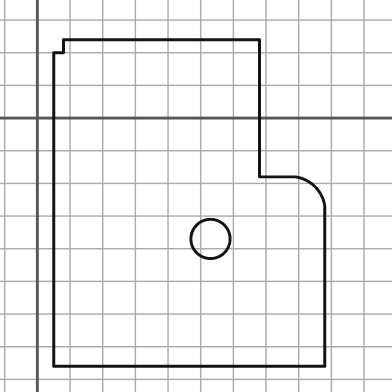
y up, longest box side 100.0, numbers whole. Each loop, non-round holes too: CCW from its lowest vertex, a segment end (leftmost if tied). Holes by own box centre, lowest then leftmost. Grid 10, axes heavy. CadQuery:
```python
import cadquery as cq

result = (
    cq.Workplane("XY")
    .moveTo(5.0, -76.0)
    .lineTo(88.0, -76.0)
    .lineTo(88.0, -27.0)
    .threePointArc((85.0, -21.0), (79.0, -18.0))
    .lineTo(68.0, -18.0)
    .lineTo(68.0, 24.0)
    .lineTo(8.0, 24.0)
    .lineTo(8.0, 20.0)
    .lineTo(5.0, 20.0)
    .close()
    .moveTo(53.0, -37.0)
    .circle(6.0)
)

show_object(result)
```